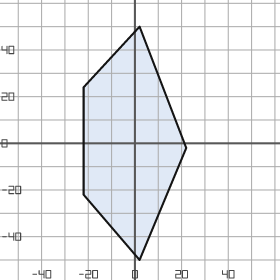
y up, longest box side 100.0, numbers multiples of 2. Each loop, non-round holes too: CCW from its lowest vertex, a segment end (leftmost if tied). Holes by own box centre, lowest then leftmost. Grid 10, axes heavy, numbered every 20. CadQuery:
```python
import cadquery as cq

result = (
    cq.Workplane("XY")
    .moveTo(2.0, -50.0)
    .lineTo(22.0, -2.0)
    .lineTo(2.0, 50.0)
    .lineTo(-22.0, 24.0)
    .lineTo(-22.0, -22.0)
    .close()
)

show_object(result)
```